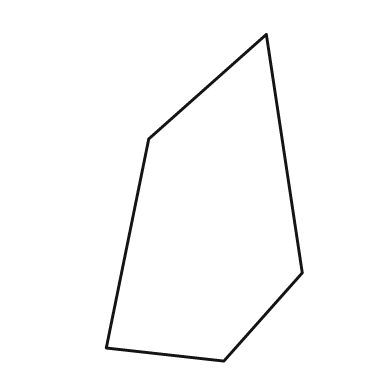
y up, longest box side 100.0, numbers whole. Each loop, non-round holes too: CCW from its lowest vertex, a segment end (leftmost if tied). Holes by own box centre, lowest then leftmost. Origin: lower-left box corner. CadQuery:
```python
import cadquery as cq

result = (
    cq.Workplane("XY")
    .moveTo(36.0, 0.0)
    .lineTo(60.0, 27.0)
    .lineTo(49.0, 100.0)
    .lineTo(13.0, 68.0)
    .lineTo(0.0, 4.0)
    .close()
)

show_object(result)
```